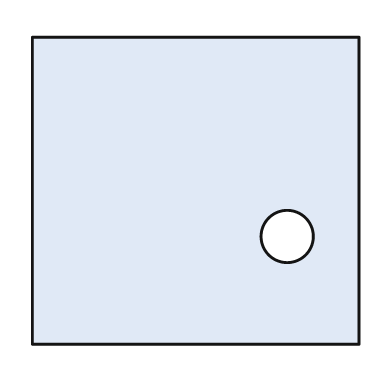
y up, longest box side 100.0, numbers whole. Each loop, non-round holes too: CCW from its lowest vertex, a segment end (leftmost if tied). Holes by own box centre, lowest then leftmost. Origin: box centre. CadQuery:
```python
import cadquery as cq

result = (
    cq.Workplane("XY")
    .moveTo(-50.0, -47.0)
    .lineTo(50.0, -47.0)
    .lineTo(50.0, 47.0)
    .lineTo(-50.0, 47.0)
    .close()
    .moveTo(28.0, -14.0)
    .circle(8.0)
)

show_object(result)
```